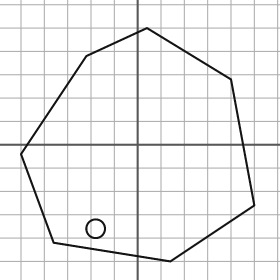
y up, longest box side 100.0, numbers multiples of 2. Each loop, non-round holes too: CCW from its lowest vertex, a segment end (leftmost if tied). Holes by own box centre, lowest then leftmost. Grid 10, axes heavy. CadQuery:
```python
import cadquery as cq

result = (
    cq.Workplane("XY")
    .moveTo(14.0, -50.0)
    .lineTo(50.0, -26.0)
    .lineTo(40.0, 28.0)
    .lineTo(4.0, 50.0)
    .lineTo(-22.0, 38.0)
    .lineTo(-50.0, -4.0)
    .lineTo(-36.0, -42.0)
    .close()
    .moveTo(-18.0, -36.0)
    .circle(4.0)
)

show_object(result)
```